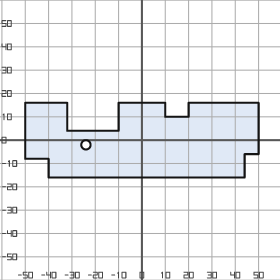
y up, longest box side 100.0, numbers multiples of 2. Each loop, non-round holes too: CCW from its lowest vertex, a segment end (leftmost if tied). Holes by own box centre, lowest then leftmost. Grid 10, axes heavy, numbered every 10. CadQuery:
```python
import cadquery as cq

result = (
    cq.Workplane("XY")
    .moveTo(-40.0, -16.0)
    .lineTo(44.0, -16.0)
    .lineTo(44.0, -6.0)
    .lineTo(50.0, -6.0)
    .lineTo(50.0, 16.0)
    .lineTo(20.0, 16.0)
    .lineTo(20.0, 10.0)
    .lineTo(10.0, 10.0)
    .lineTo(10.0, 16.0)
    .lineTo(-10.0, 16.0)
    .lineTo(-10.0, 4.0)
    .lineTo(-32.0, 4.0)
    .lineTo(-32.0, 16.0)
    .lineTo(-50.0, 16.0)
    .lineTo(-50.0, -8.0)
    .lineTo(-40.0, -8.0)
    .close()
    .moveTo(-24.0, -2.0)
    .circle(2.0)
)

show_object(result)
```